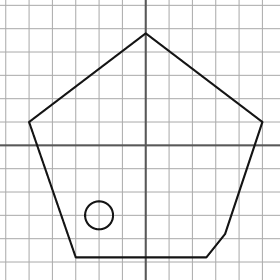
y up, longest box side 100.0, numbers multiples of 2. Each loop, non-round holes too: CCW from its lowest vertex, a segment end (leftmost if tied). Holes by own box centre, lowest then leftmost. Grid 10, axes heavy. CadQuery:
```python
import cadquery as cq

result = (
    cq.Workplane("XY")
    .moveTo(-30.0, -48.0)
    .lineTo(26.0, -48.0)
    .lineTo(34.0, -38.0)
    .lineTo(50.0, 10.0)
    .lineTo(0.0, 48.0)
    .lineTo(-50.0, 10.0)
    .close()
    .moveTo(-20.0, -30.0)
    .circle(6.0)
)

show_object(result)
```